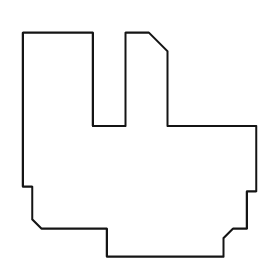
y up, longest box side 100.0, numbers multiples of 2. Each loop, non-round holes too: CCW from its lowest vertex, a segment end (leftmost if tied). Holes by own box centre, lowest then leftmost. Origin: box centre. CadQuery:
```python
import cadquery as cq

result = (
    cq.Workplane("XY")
    .moveTo(-14.0, -48.0)
    .lineTo(36.0, -48.0)
    .lineTo(36.0, -40.0)
    .lineTo(40.0, -36.0)
    .lineTo(46.0, -36.0)
    .lineTo(46.0, -20.0)
    .lineTo(50.0, -20.0)
    .lineTo(50.0, 8.0)
    .lineTo(12.0, 8.0)
    .lineTo(12.0, 40.0)
    .lineTo(4.0, 48.0)
    .lineTo(-6.0, 48.0)
    .lineTo(-6.0, 8.0)
    .lineTo(-20.0, 8.0)
    .lineTo(-20.0, 48.0)
    .lineTo(-50.0, 48.0)
    .lineTo(-50.0, -18.0)
    .lineTo(-46.0, -18.0)
    .lineTo(-46.0, -32.0)
    .lineTo(-42.0, -36.0)
    .lineTo(-14.0, -36.0)
    .close()
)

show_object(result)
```